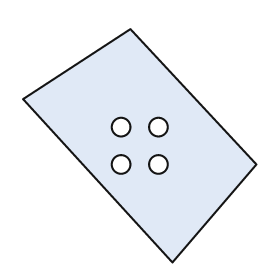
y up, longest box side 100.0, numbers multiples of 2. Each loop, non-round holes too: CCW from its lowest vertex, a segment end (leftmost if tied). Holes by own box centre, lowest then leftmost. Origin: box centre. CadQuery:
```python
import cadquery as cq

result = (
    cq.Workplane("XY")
    .moveTo(14.0, -50.0)
    .lineTo(50.0, -8.0)
    .lineTo(-4.0, 50.0)
    .lineTo(-50.0, 20.0)
    .close()
    .moveTo(-8.0, -8.0)
    .circle(4.0)
    .moveTo(8.0, -8.0)
    .circle(4.0)
    .moveTo(-8.0, 8.0)
    .circle(4.0)
    .moveTo(8.0, 8.0)
    .circle(4.0)
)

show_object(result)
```